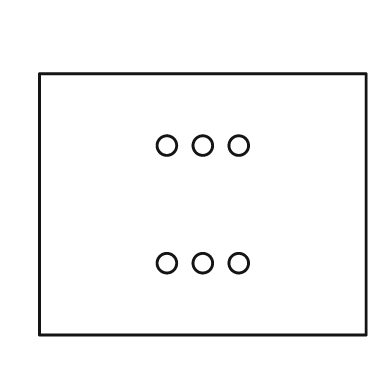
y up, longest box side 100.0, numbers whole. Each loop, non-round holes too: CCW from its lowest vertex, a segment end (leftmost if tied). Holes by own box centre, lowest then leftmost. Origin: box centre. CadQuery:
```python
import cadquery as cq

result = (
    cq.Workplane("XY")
    .moveTo(-50.0, -40.0)
    .lineTo(50.0, -40.0)
    .lineTo(50.0, 40.0)
    .lineTo(-50.0, 40.0)
    .close()
    .moveTo(-11.0, -18.0)
    .circle(3.0)
    .moveTo(0.0, -18.0)
    .circle(3.0)
    .moveTo(11.0, -18.0)
    .circle(3.0)
    .moveTo(-11.0, 18.0)
    .circle(3.0)
    .moveTo(0.0, 18.0)
    .circle(3.0)
    .moveTo(11.0, 18.0)
    .circle(3.0)
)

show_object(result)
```